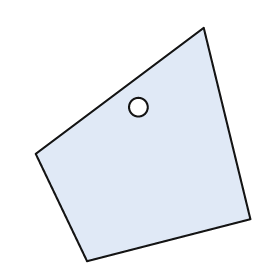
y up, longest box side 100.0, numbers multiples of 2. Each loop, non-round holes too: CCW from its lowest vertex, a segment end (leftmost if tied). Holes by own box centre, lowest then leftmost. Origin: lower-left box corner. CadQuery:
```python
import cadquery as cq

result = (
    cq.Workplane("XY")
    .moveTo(22.0, 0.0)
    .lineTo(92.0, 18.0)
    .lineTo(72.0, 100.0)
    .lineTo(0.0, 46.0)
    .close()
    .moveTo(44.0, 66.0)
    .circle(4.0)
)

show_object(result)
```